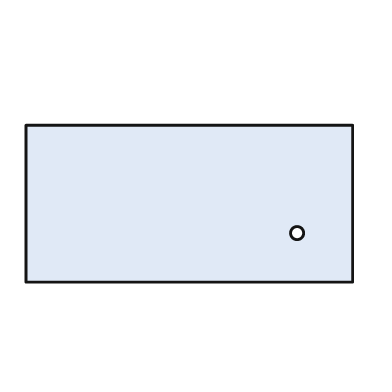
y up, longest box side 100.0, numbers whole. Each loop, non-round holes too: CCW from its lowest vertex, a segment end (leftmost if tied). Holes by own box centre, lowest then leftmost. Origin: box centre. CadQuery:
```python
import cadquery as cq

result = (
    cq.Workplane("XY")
    .moveTo(-50.0, -24.0)
    .lineTo(50.0, -24.0)
    .lineTo(50.0, 24.0)
    .lineTo(-50.0, 24.0)
    .close()
    .moveTo(33.0, -9.0)
    .circle(2.0)
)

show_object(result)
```